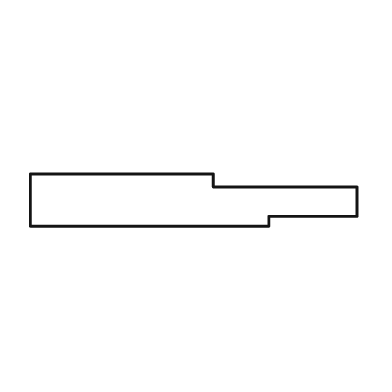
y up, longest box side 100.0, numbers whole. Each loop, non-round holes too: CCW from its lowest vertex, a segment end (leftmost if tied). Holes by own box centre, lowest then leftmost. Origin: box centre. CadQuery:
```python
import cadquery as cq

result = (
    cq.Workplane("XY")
    .moveTo(-50.0, -8.0)
    .lineTo(23.0, -8.0)
    .lineTo(23.0, -5.0)
    .lineTo(50.0, -5.0)
    .lineTo(50.0, 4.0)
    .lineTo(6.0, 4.0)
    .lineTo(6.0, 8.0)
    .lineTo(-50.0, 8.0)
    .close()
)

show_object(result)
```